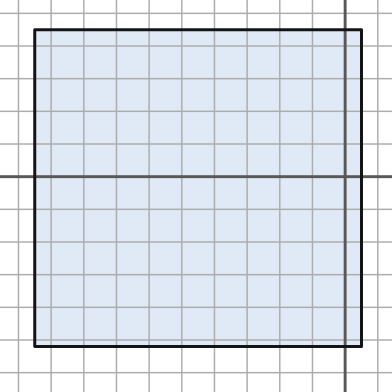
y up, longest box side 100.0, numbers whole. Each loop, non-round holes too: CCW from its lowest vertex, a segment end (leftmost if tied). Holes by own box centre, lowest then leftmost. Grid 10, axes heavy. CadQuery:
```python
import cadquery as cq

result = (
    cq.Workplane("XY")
    .moveTo(-95.0, -52.0)
    .lineTo(5.0, -52.0)
    .lineTo(5.0, 45.0)
    .lineTo(-95.0, 45.0)
    .close()
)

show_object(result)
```